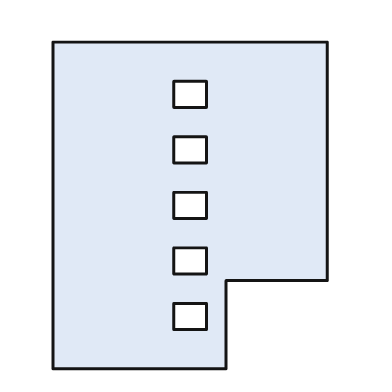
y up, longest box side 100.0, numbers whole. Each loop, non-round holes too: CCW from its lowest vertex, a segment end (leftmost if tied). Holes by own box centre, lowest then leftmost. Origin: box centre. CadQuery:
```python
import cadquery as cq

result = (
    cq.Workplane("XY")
    .moveTo(-42.0, -50.0)
    .lineTo(11.0, -50.0)
    .lineTo(11.0, -23.0)
    .lineTo(42.0, -23.0)
    .lineTo(42.0, 50.0)
    .lineTo(-42.0, 50.0)
    .close()
    .moveTo(-5.0, -38.0)
    .lineTo(5.0, -38.0)
    .lineTo(5.0, -30.0)
    .lineTo(-5.0, -30.0)
    .close()
    .moveTo(-5.0, -21.0)
    .lineTo(5.0, -21.0)
    .lineTo(5.0, -13.0)
    .lineTo(-5.0, -13.0)
    .close()
    .moveTo(-5.0, -4.0)
    .lineTo(5.0, -4.0)
    .lineTo(5.0, 4.0)
    .lineTo(-5.0, 4.0)
    .close()
    .moveTo(-5.0, 13.0)
    .lineTo(5.0, 13.0)
    .lineTo(5.0, 21.0)
    .lineTo(-5.0, 21.0)
    .close()
    .moveTo(-5.0, 30.0)
    .lineTo(5.0, 30.0)
    .lineTo(5.0, 38.0)
    .lineTo(-5.0, 38.0)
    .close()
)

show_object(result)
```